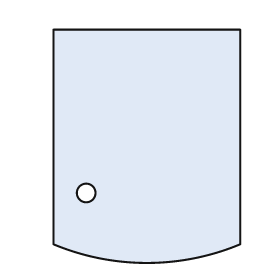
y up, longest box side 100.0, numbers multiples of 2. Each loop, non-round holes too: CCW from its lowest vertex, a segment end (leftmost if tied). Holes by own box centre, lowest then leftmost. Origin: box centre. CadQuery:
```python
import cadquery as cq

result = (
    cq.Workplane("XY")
    .moveTo(-40.0, -42.0)
    .threePointArc((0.0, -50.0), (40.0, -42.0))
    .lineTo(40.0, 50.0)
    .lineTo(-40.0, 50.0)
    .close()
    .moveTo(-26.0, -20.0)
    .circle(4.0)
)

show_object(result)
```